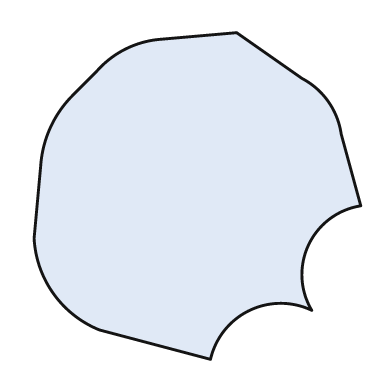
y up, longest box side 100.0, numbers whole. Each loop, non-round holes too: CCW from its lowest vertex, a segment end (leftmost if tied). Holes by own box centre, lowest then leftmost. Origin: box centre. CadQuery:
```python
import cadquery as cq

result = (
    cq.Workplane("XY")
    .moveTo(4.0, -50.0)
    .threePointArc((16.0, -35.0), (35.0, -35.0))
    .threePointArc((34.0, -15.0), (50.0, -3.0))
    .lineTo(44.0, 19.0)
    .threePointArc((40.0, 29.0), (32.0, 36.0))
    .lineTo(12.0, 50.0)
    .lineTo(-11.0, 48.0)
    .threePointArc((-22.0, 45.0), (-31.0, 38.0))
    .lineTo(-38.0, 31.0)
    .threePointArc((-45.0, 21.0), (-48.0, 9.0))
    .lineTo(-50.0, -13.0)
    .threePointArc((-44.0, -30.0), (-30.0, -41.0))
    .close()
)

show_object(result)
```